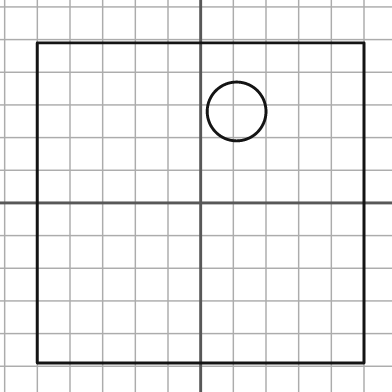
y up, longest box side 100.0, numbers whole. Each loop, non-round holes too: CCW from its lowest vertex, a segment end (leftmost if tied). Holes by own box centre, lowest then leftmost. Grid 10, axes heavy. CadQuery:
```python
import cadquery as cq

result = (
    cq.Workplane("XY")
    .moveTo(-50.0, -49.0)
    .lineTo(50.0, -49.0)
    .lineTo(50.0, 49.0)
    .lineTo(-50.0, 49.0)
    .close()
    .moveTo(11.0, 28.0)
    .circle(9.0)
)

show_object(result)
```